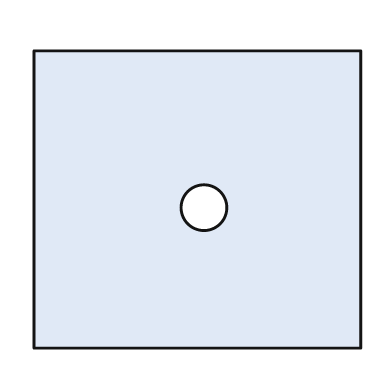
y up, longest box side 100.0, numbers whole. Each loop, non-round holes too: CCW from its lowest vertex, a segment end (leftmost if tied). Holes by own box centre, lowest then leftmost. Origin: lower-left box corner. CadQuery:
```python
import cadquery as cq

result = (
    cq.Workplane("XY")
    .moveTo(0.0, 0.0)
    .lineTo(100.0, 0.0)
    .lineTo(100.0, 91.0)
    .lineTo(0.0, 91.0)
    .close()
    .moveTo(52.0, 43.0)
    .circle(7.0)
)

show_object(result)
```